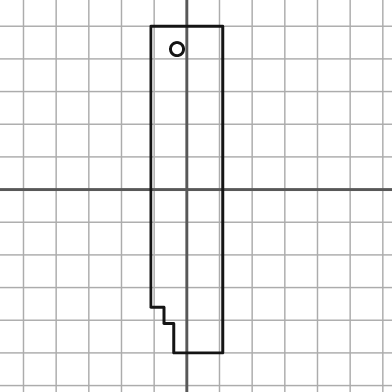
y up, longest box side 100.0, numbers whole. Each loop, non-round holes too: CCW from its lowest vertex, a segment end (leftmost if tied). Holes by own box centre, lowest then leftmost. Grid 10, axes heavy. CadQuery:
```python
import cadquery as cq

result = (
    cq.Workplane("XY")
    .moveTo(-4.0, -50.0)
    .lineTo(11.0, -50.0)
    .lineTo(11.0, 50.0)
    .lineTo(-11.0, 50.0)
    .lineTo(-11.0, -36.0)
    .lineTo(-7.0, -36.0)
    .lineTo(-7.0, -41.0)
    .lineTo(-4.0, -41.0)
    .close()
    .moveTo(-3.0, 43.0)
    .circle(2.0)
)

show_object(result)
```